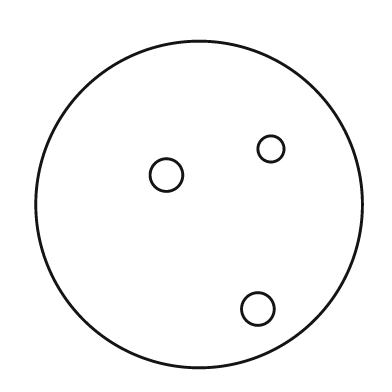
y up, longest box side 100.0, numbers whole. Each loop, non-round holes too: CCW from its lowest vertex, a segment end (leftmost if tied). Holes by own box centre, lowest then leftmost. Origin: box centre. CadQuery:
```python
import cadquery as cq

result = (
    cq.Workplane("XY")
    .moveTo(0.0, 0.0)
    .circle(50.0)
    .moveTo(18.0, -32.0)
    .circle(5.0)
    .moveTo(-10.0, 9.0)
    .circle(5.0)
    .moveTo(22.0, 17.0)
    .circle(4.0)
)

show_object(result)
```